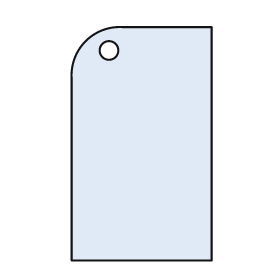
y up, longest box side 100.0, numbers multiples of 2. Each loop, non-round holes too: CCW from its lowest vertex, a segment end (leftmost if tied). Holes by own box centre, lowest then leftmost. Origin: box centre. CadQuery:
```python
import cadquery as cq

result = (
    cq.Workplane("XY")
    .moveTo(-30.0, -50.0)
    .lineTo(30.0, -50.0)
    .lineTo(30.0, 50.0)
    .lineTo(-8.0, 50.0)
    .threePointArc((-24.0, 44.0), (-30.0, 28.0))
    .close()
    .moveTo(-14.0, 40.0)
    .circle(4.0)
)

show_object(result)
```